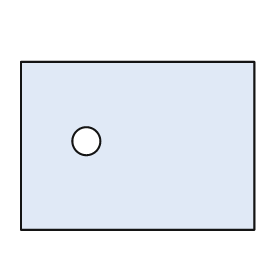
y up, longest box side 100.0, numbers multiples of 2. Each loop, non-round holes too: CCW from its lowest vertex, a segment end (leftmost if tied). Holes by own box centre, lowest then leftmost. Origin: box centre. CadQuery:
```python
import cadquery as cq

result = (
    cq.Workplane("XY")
    .moveTo(-50.0, -36.0)
    .lineTo(50.0, -36.0)
    .lineTo(50.0, 36.0)
    .lineTo(-50.0, 36.0)
    .close()
    .moveTo(-22.0, 2.0)
    .circle(6.0)
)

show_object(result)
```